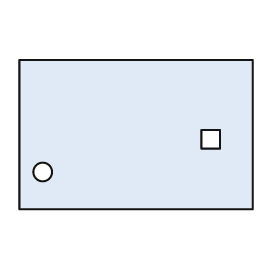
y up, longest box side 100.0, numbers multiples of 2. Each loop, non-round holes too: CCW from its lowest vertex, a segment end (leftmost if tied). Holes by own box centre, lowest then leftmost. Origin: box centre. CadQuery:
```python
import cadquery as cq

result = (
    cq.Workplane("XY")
    .moveTo(-50.0, -32.0)
    .lineTo(50.0, -32.0)
    .lineTo(50.0, 32.0)
    .lineTo(-50.0, 32.0)
    .close()
    .moveTo(-40.0, -16.0)
    .circle(4.0)
    .moveTo(28.0, -6.0)
    .lineTo(36.0, -6.0)
    .lineTo(36.0, 2.0)
    .lineTo(28.0, 2.0)
    .close()
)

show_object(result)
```